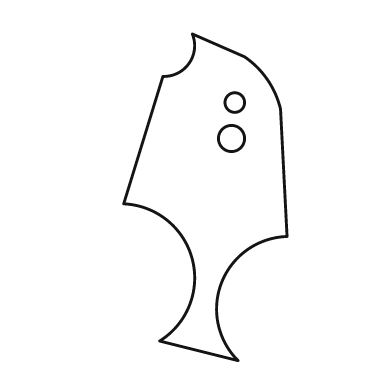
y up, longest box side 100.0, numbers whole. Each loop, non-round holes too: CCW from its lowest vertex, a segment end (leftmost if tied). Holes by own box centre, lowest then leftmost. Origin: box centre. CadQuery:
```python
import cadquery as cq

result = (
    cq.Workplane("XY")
    .moveTo(10.0, -50.0)
    .threePointArc((5.0, -26.0), (25.0, -12.0))
    .lineTo(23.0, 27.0)
    .threePointArc((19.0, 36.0), (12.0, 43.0))
    .lineTo(-4.0, 50.0)
    .threePointArc((-5.0, 41.0), (-13.0, 37.0))
    .lineTo(-25.0, -2.0)
    .threePointArc((-4.0, -19.0), (-14.0, -44.0))
    .close()
    .moveTo(8.0, 18.0)
    .circle(4.0)
    .moveTo(9.0, 29.0)
    .circle(3.0)
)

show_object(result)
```